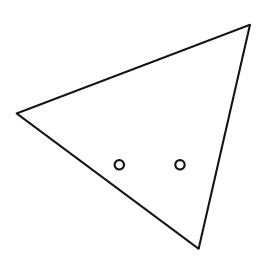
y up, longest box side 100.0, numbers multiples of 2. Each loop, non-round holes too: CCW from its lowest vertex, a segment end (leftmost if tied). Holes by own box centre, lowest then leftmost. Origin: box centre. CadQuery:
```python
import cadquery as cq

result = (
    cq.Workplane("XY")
    .moveTo(28.0, -48.0)
    .lineTo(50.0, 48.0)
    .lineTo(-50.0, 10.0)
    .close()
    .moveTo(-6.0, -12.0)
    .circle(2.0)
    .moveTo(20.0, -12.0)
    .circle(2.0)
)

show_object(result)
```